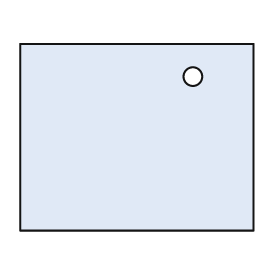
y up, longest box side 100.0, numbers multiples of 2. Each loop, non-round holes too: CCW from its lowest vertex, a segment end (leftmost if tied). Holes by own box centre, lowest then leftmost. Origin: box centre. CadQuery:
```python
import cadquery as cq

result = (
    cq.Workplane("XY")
    .moveTo(-50.0, -40.0)
    .lineTo(50.0, -40.0)
    .lineTo(50.0, 40.0)
    .lineTo(-50.0, 40.0)
    .close()
    .moveTo(24.0, 26.0)
    .circle(4.0)
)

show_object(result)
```